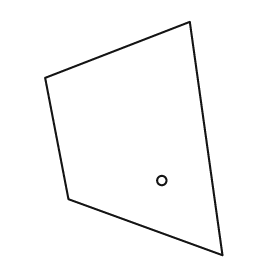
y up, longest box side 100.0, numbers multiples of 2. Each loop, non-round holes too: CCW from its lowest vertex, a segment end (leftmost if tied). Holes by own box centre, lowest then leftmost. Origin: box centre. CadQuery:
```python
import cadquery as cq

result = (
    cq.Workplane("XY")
    .moveTo(38.0, -50.0)
    .lineTo(24.0, 50.0)
    .lineTo(-38.0, 26.0)
    .lineTo(-28.0, -26.0)
    .close()
    .moveTo(12.0, -18.0)
    .circle(2.0)
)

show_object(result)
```